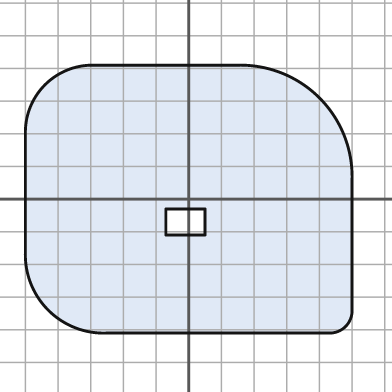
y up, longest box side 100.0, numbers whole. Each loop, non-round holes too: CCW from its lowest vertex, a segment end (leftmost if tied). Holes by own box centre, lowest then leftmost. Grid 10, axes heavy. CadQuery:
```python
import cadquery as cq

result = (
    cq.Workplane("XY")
    .moveTo(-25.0, -41.0)
    .lineTo(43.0, -41.0)
    .threePointArc((48.0, -39.0), (50.0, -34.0))
    .lineTo(50.0, 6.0)
    .threePointArc((40.0, 31.0), (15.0, 41.0))
    .lineTo(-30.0, 41.0)
    .threePointArc((-44.0, 35.0), (-50.0, 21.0))
    .lineTo(-50.0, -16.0)
    .threePointArc((-43.0, -34.0), (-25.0, -41.0))
    .close()
    .moveTo(-7.0, -11.0)
    .lineTo(5.0, -11.0)
    .lineTo(5.0, -3.0)
    .lineTo(-7.0, -3.0)
    .close()
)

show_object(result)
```